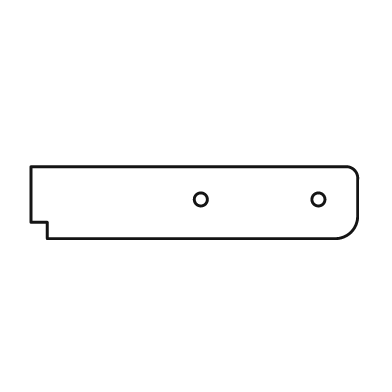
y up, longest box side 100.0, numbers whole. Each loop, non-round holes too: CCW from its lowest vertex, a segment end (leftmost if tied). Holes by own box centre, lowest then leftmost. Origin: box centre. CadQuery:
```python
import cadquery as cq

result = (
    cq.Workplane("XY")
    .moveTo(-45.0, -11.0)
    .lineTo(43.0, -11.0)
    .threePointArc((48.0, -9.0), (50.0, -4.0))
    .lineTo(50.0, 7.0)
    .threePointArc((49.0, 10.0), (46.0, 11.0))
    .lineTo(-50.0, 11.0)
    .lineTo(-50.0, -6.0)
    .lineTo(-45.0, -6.0)
    .close()
    .moveTo(2.0, 1.0)
    .circle(2.0)
    .moveTo(38.0, 1.0)
    .circle(2.0)
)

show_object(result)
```